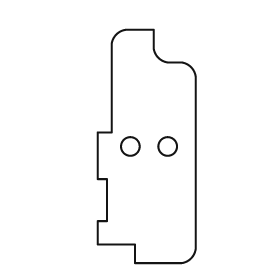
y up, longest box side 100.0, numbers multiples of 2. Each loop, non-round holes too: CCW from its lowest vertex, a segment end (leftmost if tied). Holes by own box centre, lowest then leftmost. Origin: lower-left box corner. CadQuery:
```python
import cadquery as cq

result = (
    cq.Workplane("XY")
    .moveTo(16.0, 0.0)
    .lineTo(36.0, 0.0)
    .threePointArc((40.0, 2.0), (42.0, 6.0))
    .lineTo(42.0, 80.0)
    .threePointArc((40.0, 84.0), (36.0, 86.0))
    .lineTo(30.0, 86.0)
    .threePointArc((26.0, 88.0), (24.0, 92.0))
    .lineTo(24.0, 100.0)
    .lineTo(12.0, 100.0)
    .threePointArc((8.0, 98.0), (6.0, 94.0))
    .lineTo(6.0, 56.0)
    .lineTo(0.0, 56.0)
    .lineTo(0.0, 36.0)
    .lineTo(4.0, 36.0)
    .lineTo(4.0, 18.0)
    .lineTo(0.0, 18.0)
    .lineTo(0.0, 8.0)
    .lineTo(16.0, 8.0)
    .close()
    .moveTo(14.0, 50.0)
    .circle(4.0)
    .moveTo(30.0, 50.0)
    .circle(4.0)
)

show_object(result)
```